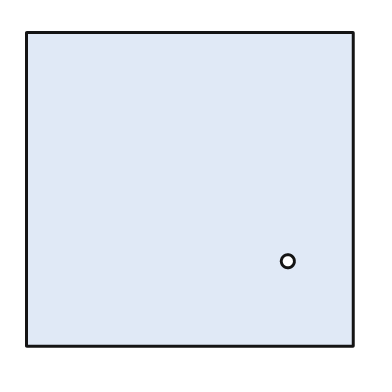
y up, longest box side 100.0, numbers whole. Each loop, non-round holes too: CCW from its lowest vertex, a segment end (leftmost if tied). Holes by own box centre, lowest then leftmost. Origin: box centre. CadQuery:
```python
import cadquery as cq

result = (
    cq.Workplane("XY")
    .moveTo(-50.0, -48.0)
    .lineTo(50.0, -48.0)
    .lineTo(50.0, 48.0)
    .lineTo(-50.0, 48.0)
    .close()
    .moveTo(30.0, -22.0)
    .circle(2.0)
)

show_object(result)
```